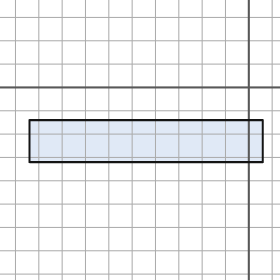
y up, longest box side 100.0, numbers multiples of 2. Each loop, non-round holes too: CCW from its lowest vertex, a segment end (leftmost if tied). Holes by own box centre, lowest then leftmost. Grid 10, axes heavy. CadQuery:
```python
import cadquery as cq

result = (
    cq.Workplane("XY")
    .moveTo(-94.0, -32.0)
    .lineTo(6.0, -32.0)
    .lineTo(6.0, -14.0)
    .lineTo(-94.0, -14.0)
    .close()
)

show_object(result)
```